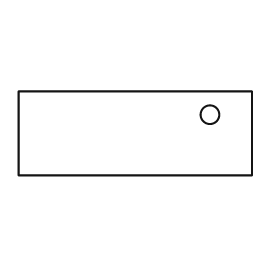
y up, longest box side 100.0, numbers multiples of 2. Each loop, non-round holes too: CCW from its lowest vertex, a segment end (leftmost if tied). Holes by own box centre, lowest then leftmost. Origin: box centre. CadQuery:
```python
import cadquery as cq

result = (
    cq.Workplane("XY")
    .moveTo(-50.0, -18.0)
    .lineTo(50.0, -18.0)
    .lineTo(50.0, 18.0)
    .lineTo(-50.0, 18.0)
    .close()
    .moveTo(32.0, 8.0)
    .circle(4.0)
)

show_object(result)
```